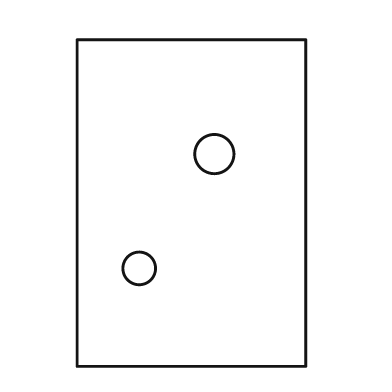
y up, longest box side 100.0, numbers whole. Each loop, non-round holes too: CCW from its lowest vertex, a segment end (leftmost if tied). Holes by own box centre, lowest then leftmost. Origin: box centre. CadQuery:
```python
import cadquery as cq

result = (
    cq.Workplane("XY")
    .moveTo(-35.0, -50.0)
    .lineTo(35.0, -50.0)
    .lineTo(35.0, 50.0)
    .lineTo(-35.0, 50.0)
    .close()
    .moveTo(-16.0, -20.0)
    .circle(5.0)
    .moveTo(7.0, 15.0)
    .circle(6.0)
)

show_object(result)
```